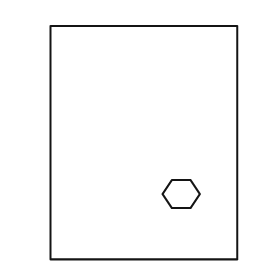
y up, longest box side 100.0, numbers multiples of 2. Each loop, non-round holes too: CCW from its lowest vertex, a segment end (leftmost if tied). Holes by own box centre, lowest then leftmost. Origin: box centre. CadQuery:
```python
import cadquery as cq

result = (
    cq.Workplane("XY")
    .moveTo(-40.0, -50.0)
    .lineTo(40.0, -50.0)
    .lineTo(40.0, 50.0)
    .lineTo(-40.0, 50.0)
    .close()
    .moveTo(12.0, -28.0)
    .lineTo(20.0, -28.0)
    .lineTo(24.0, -22.0)
    .lineTo(20.0, -16.0)
    .lineTo(12.0, -16.0)
    .lineTo(8.0, -22.0)
    .close()
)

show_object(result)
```